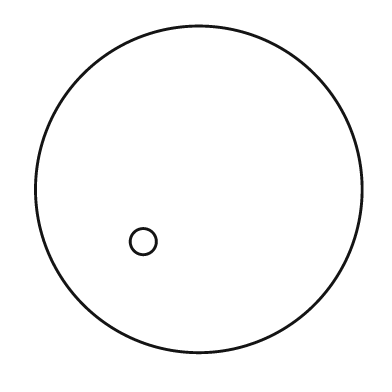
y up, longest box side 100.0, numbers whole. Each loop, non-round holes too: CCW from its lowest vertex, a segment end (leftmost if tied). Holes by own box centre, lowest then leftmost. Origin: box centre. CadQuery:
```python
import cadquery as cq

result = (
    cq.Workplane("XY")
    .moveTo(0.0, 0.0)
    .circle(50.0)
    .moveTo(-17.0, -16.0)
    .circle(4.0)
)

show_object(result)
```